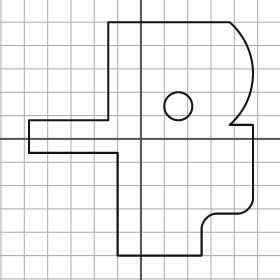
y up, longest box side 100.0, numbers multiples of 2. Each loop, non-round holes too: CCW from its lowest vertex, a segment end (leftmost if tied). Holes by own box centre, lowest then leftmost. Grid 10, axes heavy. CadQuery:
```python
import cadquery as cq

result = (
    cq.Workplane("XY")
    .moveTo(-10.0, -50.0)
    .lineTo(26.0, -50.0)
    .lineTo(26.0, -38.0)
    .threePointArc((28.0, -34.0), (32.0, -32.0))
    .lineTo(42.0, -32.0)
    .threePointArc((46.0, -30.0), (48.0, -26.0))
    .lineTo(48.0, 6.0)
    .lineTo(38.0, 6.0)
    .threePointArc((48.0, 28.0), (38.0, 50.0))
    .lineTo(-14.0, 50.0)
    .lineTo(-14.0, 8.0)
    .lineTo(-48.0, 8.0)
    .lineTo(-48.0, -6.0)
    .lineTo(-10.0, -6.0)
    .close()
    .moveTo(16.0, 14.0)
    .circle(6.0)
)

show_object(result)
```